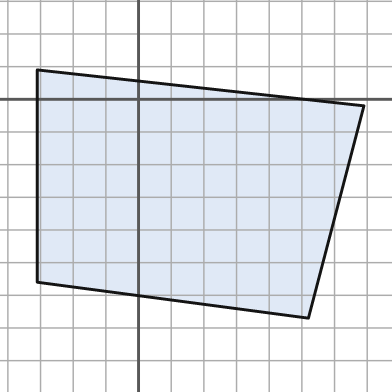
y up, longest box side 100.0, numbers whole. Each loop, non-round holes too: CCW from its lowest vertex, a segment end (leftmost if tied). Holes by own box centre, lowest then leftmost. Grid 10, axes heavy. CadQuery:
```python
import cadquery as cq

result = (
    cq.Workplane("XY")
    .moveTo(52.0, -67.0)
    .lineTo(69.0, -2.0)
    .lineTo(-31.0, 9.0)
    .lineTo(-31.0, -56.0)
    .close()
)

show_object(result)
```